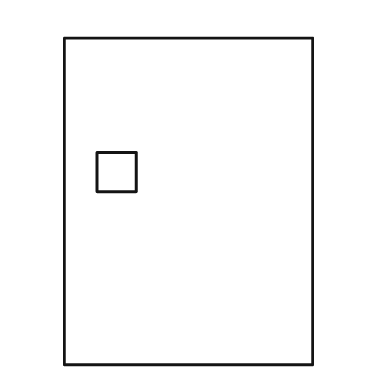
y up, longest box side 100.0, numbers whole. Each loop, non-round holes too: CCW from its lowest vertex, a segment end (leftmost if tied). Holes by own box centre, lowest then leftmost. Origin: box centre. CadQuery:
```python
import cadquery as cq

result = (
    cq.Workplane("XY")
    .moveTo(-38.0, -50.0)
    .lineTo(38.0, -50.0)
    .lineTo(38.0, 50.0)
    .lineTo(-38.0, 50.0)
    .close()
    .moveTo(-28.0, 3.0)
    .lineTo(-16.0, 3.0)
    .lineTo(-16.0, 15.0)
    .lineTo(-28.0, 15.0)
    .close()
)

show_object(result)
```